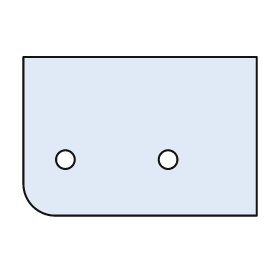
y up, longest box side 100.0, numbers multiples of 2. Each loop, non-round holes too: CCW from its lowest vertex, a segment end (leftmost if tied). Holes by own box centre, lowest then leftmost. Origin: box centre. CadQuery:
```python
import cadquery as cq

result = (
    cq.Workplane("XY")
    .moveTo(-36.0, -34.0)
    .lineTo(50.0, -34.0)
    .lineTo(50.0, 34.0)
    .lineTo(-50.0, 34.0)
    .lineTo(-50.0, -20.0)
    .threePointArc((-46.0, -30.0), (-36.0, -34.0))
    .close()
    .moveTo(-32.0, -10.0)
    .circle(4.0)
    .moveTo(12.0, -10.0)
    .circle(4.0)
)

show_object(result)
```